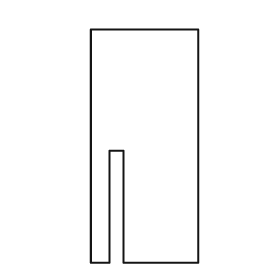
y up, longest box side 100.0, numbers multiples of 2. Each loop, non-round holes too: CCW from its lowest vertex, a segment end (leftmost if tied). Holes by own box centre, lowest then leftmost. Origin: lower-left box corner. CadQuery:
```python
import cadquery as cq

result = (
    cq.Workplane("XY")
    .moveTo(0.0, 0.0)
    .lineTo(8.0, 0.0)
    .lineTo(8.0, 48.0)
    .lineTo(14.0, 48.0)
    .lineTo(14.0, 0.0)
    .lineTo(46.0, 0.0)
    .lineTo(46.0, 100.0)
    .lineTo(0.0, 100.0)
    .close()
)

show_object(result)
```